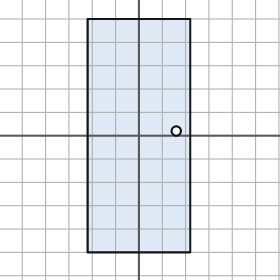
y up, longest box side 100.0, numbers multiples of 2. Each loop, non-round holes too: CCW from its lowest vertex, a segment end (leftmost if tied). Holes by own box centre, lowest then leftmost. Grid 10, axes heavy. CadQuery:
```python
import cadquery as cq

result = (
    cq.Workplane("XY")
    .moveTo(-22.0, -50.0)
    .lineTo(22.0, -50.0)
    .lineTo(22.0, 50.0)
    .lineTo(-22.0, 50.0)
    .close()
    .moveTo(16.0, 2.0)
    .circle(2.0)
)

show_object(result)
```